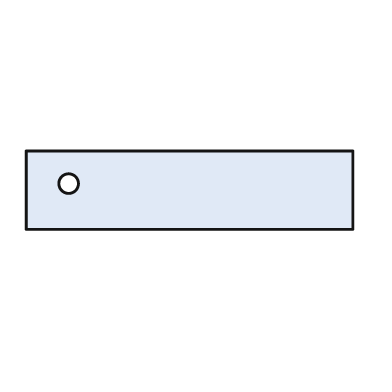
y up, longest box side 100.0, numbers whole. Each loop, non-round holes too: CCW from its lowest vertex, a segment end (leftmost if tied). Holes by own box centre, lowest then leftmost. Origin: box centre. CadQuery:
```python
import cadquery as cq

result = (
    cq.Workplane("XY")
    .moveTo(-50.0, -12.0)
    .lineTo(50.0, -12.0)
    .lineTo(50.0, 12.0)
    .lineTo(-50.0, 12.0)
    .close()
    .moveTo(-37.0, 2.0)
    .circle(3.0)
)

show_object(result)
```